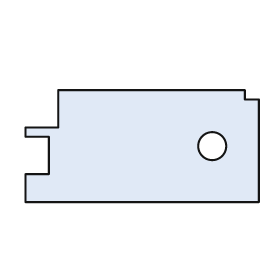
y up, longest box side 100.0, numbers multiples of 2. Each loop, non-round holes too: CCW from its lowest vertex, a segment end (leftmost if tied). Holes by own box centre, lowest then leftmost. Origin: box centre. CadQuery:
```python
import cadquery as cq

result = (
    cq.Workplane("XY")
    .moveTo(-50.0, -24.0)
    .lineTo(50.0, -24.0)
    .lineTo(50.0, 20.0)
    .lineTo(44.0, 20.0)
    .lineTo(44.0, 24.0)
    .lineTo(-36.0, 24.0)
    .lineTo(-36.0, 8.0)
    .lineTo(-50.0, 8.0)
    .lineTo(-50.0, 4.0)
    .lineTo(-40.0, 4.0)
    .lineTo(-40.0, -12.0)
    .lineTo(-50.0, -12.0)
    .close()
    .moveTo(30.0, 0.0)
    .circle(6.0)
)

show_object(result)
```